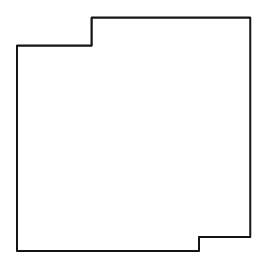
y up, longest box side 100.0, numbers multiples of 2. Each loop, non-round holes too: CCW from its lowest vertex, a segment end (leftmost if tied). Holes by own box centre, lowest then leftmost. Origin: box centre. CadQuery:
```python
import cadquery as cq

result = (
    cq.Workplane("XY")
    .moveTo(-50.0, -50.0)
    .lineTo(28.0, -50.0)
    .lineTo(28.0, -44.0)
    .lineTo(50.0, -44.0)
    .lineTo(50.0, 50.0)
    .lineTo(-18.0, 50.0)
    .lineTo(-18.0, 38.0)
    .lineTo(-50.0, 38.0)
    .close()
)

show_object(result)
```